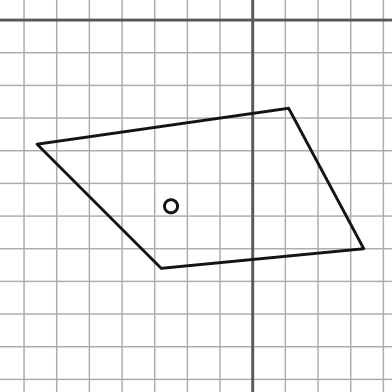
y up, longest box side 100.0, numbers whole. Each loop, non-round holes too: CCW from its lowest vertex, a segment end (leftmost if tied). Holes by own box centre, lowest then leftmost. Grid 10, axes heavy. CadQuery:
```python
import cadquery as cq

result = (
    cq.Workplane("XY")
    .moveTo(-28.0, -76.0)
    .lineTo(34.0, -70.0)
    .lineTo(11.0, -27.0)
    .lineTo(-66.0, -38.0)
    .close()
    .moveTo(-25.0, -57.0)
    .circle(2.0)
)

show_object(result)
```